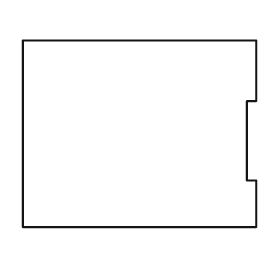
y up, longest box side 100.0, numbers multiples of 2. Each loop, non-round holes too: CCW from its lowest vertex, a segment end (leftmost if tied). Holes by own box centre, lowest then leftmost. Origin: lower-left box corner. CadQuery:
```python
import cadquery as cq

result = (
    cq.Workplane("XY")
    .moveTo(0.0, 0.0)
    .lineTo(100.0, 0.0)
    .lineTo(100.0, 20.0)
    .lineTo(96.0, 20.0)
    .lineTo(96.0, 54.0)
    .lineTo(100.0, 54.0)
    .lineTo(100.0, 80.0)
    .lineTo(0.0, 80.0)
    .close()
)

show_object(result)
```